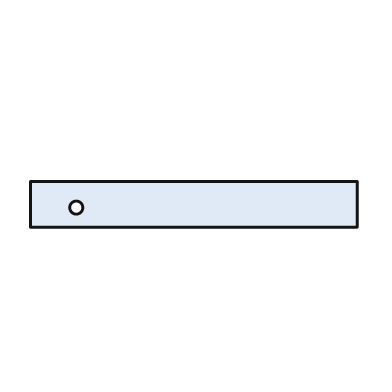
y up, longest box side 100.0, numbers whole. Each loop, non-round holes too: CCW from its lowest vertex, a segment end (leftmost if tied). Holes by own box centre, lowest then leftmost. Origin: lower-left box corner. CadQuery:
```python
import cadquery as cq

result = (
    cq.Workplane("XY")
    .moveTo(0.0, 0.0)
    .lineTo(100.0, 0.0)
    .lineTo(100.0, 14.0)
    .lineTo(0.0, 14.0)
    .close()
    .moveTo(14.0, 6.0)
    .circle(2.0)
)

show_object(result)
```